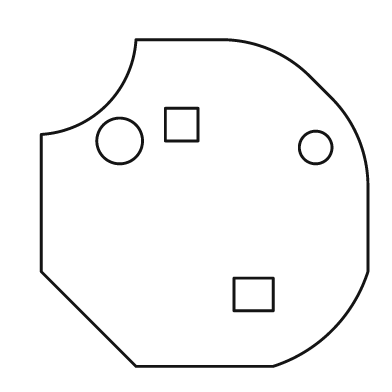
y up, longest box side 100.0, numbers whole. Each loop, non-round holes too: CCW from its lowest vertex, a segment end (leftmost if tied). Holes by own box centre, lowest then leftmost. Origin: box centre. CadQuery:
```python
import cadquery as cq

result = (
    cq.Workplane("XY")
    .moveTo(-21.0, -50.0)
    .lineTo(21.0, -50.0)
    .threePointArc((39.0, -39.0), (50.0, -21.0))
    .lineTo(50.0, 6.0)
    .threePointArc((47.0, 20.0), (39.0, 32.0))
    .lineTo(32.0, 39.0)
    .threePointArc((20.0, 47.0), (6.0, 50.0))
    .lineTo(-21.0, 50.0)
    .threePointArc((-30.0, 30.0), (-50.0, 21.0))
    .lineTo(-50.0, -21.0)
    .close()
    .moveTo(9.0, -33.0)
    .lineTo(21.0, -33.0)
    .lineTo(21.0, -23.0)
    .lineTo(9.0, -23.0)
    .close()
    .moveTo(34.0, 17.0)
    .circle(5.0)
    .moveTo(-26.0, 19.0)
    .circle(7.0)
    .moveTo(-12.0, 19.0)
    .lineTo(-2.0, 19.0)
    .lineTo(-2.0, 29.0)
    .lineTo(-12.0, 29.0)
    .close()
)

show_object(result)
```